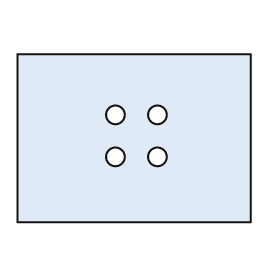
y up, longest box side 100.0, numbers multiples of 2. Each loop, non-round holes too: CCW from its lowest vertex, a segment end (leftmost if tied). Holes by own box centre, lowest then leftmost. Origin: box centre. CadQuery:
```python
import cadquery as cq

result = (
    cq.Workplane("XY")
    .moveTo(-50.0, -36.0)
    .lineTo(50.0, -36.0)
    .lineTo(50.0, 36.0)
    .lineTo(-50.0, 36.0)
    .close()
    .moveTo(-8.0, -8.0)
    .circle(4.0)
    .moveTo(10.0, -8.0)
    .circle(4.0)
    .moveTo(-8.0, 10.0)
    .circle(4.0)
    .moveTo(10.0, 10.0)
    .circle(4.0)
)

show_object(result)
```